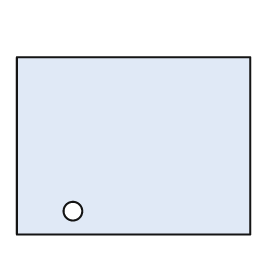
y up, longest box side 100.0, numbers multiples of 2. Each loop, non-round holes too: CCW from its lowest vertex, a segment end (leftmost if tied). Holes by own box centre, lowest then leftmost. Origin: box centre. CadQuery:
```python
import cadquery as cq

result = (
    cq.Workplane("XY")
    .moveTo(-50.0, -38.0)
    .lineTo(50.0, -38.0)
    .lineTo(50.0, 38.0)
    .lineTo(-50.0, 38.0)
    .close()
    .moveTo(-26.0, -28.0)
    .circle(4.0)
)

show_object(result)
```